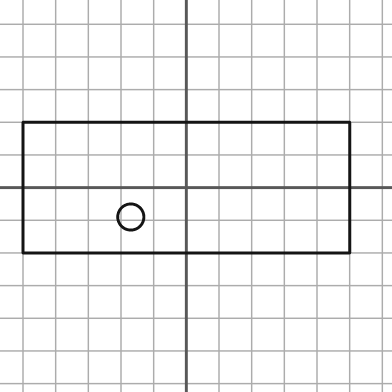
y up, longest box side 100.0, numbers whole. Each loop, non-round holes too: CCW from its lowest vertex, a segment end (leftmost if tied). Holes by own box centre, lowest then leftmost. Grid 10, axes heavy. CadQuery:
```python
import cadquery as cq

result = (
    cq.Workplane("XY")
    .moveTo(-50.0, -20.0)
    .lineTo(50.0, -20.0)
    .lineTo(50.0, 20.0)
    .lineTo(-50.0, 20.0)
    .close()
    .moveTo(-17.0, -9.0)
    .circle(4.0)
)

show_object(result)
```